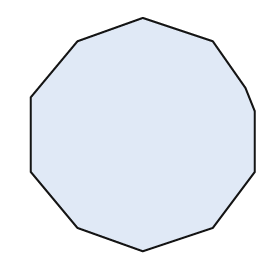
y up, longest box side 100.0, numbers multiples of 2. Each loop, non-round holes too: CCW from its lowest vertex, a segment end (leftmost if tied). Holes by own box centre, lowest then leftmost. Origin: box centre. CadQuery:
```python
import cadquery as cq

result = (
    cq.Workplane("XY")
    .moveTo(0.0, -50.0)
    .lineTo(30.0, -40.0)
    .lineTo(48.0, -16.0)
    .lineTo(48.0, 10.0)
    .lineTo(44.0, 20.0)
    .lineTo(30.0, 40.0)
    .lineTo(0.0, 50.0)
    .lineTo(-28.0, 40.0)
    .lineTo(-48.0, 16.0)
    .lineTo(-48.0, -16.0)
    .lineTo(-28.0, -40.0)
    .close()
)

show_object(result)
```